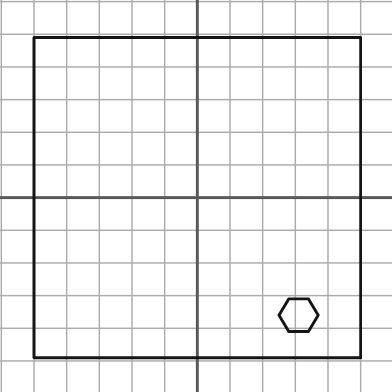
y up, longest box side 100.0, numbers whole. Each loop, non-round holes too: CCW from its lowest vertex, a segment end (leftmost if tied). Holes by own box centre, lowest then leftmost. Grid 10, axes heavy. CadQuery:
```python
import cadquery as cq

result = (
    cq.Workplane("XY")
    .moveTo(-50.0, -49.0)
    .lineTo(50.0, -49.0)
    .lineTo(50.0, 49.0)
    .lineTo(-50.0, 49.0)
    .close()
    .moveTo(28.0, -41.0)
    .lineTo(34.0, -41.0)
    .lineTo(37.0, -36.0)
    .lineTo(34.0, -31.0)
    .lineTo(28.0, -31.0)
    .lineTo(25.0, -36.0)
    .close()
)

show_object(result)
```